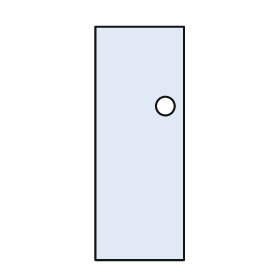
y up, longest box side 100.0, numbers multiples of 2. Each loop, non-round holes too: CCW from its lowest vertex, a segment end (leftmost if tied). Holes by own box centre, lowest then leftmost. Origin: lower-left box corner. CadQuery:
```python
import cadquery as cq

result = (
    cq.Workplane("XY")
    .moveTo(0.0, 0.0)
    .lineTo(38.0, 0.0)
    .lineTo(38.0, 100.0)
    .lineTo(0.0, 100.0)
    .close()
    .moveTo(30.0, 66.0)
    .circle(4.0)
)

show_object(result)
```